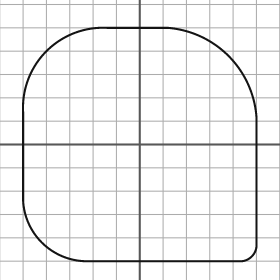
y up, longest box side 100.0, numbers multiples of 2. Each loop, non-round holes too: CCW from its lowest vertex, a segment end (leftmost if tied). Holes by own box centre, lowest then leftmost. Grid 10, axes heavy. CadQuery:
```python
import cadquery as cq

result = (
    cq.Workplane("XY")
    .moveTo(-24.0, -50.0)
    .lineTo(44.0, -50.0)
    .threePointArc((48.0, -48.0), (50.0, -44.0))
    .lineTo(50.0, 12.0)
    .threePointArc((38.0, 38.0), (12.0, 50.0))
    .lineTo(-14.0, 50.0)
    .threePointArc((-40.0, 40.0), (-50.0, 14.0))
    .lineTo(-50.0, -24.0)
    .threePointArc((-42.0, -42.0), (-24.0, -50.0))
    .close()
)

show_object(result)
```